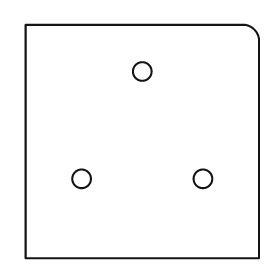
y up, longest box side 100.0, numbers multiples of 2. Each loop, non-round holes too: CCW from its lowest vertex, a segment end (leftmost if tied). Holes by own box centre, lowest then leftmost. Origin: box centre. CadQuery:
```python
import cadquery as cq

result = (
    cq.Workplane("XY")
    .moveTo(-50.0, -50.0)
    .lineTo(50.0, -50.0)
    .lineTo(50.0, 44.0)
    .threePointArc((48.0, 48.0), (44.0, 50.0))
    .lineTo(-50.0, 50.0)
    .close()
    .moveTo(-26.0, -16.0)
    .circle(4.0)
    .moveTo(26.0, -16.0)
    .circle(4.0)
    .moveTo(0.0, 30.0)
    .circle(4.0)
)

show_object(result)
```